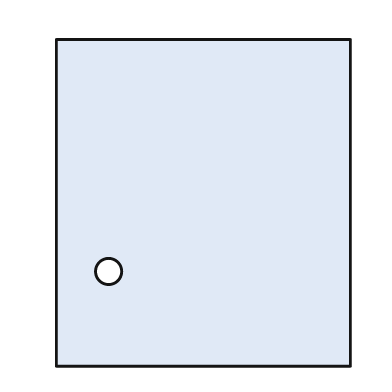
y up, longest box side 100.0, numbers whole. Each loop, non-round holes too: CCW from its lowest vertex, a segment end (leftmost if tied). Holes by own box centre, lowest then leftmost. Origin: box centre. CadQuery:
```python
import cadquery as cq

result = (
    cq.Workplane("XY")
    .moveTo(-45.0, -50.0)
    .lineTo(45.0, -50.0)
    .lineTo(45.0, 50.0)
    .lineTo(-45.0, 50.0)
    .close()
    .moveTo(-29.0, -21.0)
    .circle(4.0)
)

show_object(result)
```